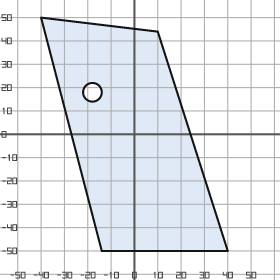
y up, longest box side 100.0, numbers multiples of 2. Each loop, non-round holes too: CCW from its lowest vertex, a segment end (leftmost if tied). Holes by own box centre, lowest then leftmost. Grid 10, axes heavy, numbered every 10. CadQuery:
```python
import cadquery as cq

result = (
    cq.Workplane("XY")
    .moveTo(-14.0, -50.0)
    .lineTo(40.0, -50.0)
    .lineTo(10.0, 44.0)
    .lineTo(-40.0, 50.0)
    .close()
    .moveTo(-18.0, 18.0)
    .circle(4.0)
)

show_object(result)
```